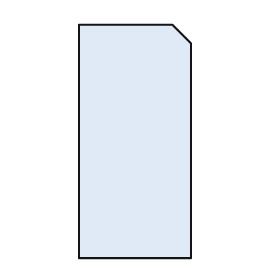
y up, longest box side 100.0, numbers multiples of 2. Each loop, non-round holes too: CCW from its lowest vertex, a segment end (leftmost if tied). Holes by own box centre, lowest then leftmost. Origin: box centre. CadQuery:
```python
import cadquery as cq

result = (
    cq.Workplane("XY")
    .moveTo(-24.0, -50.0)
    .lineTo(24.0, -50.0)
    .lineTo(24.0, 42.0)
    .lineTo(16.0, 50.0)
    .lineTo(-24.0, 50.0)
    .close()
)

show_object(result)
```